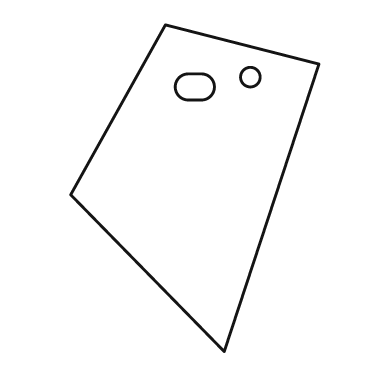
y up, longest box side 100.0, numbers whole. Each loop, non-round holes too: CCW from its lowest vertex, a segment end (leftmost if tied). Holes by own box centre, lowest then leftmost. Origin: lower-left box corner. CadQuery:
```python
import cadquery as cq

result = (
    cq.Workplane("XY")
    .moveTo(47.0, 0.0)
    .lineTo(76.0, 88.0)
    .lineTo(29.0, 100.0)
    .lineTo(0.0, 48.0)
    .close()
    .moveTo(36.0, 77.0)
    .lineTo(40.0, 77.0)
    .threePointArc((44.0, 81.0), (40.0, 85.0))
    .lineTo(36.0, 85.0)
    .threePointArc((32.0, 81.0), (36.0, 77.0))
    .close()
    .moveTo(55.0, 84.0)
    .circle(3.0)
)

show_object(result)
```